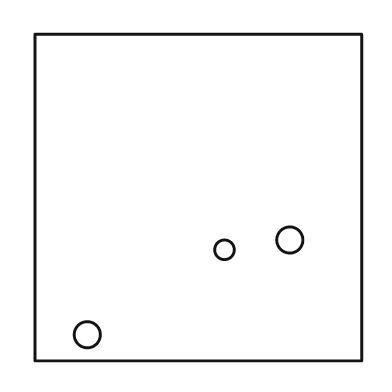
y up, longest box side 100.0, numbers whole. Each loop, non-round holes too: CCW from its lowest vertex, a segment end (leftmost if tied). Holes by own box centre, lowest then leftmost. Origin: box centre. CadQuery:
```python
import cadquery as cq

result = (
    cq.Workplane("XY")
    .moveTo(-50.0, -50.0)
    .lineTo(50.0, -50.0)
    .lineTo(50.0, 50.0)
    .lineTo(-50.0, 50.0)
    .close()
    .moveTo(-34.0, -42.0)
    .circle(4.0)
    .moveTo(8.0, -16.0)
    .circle(3.0)
    .moveTo(28.0, -13.0)
    .circle(4.0)
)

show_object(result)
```